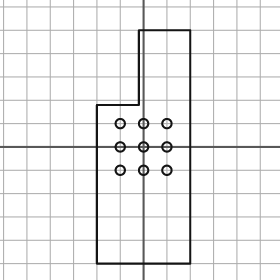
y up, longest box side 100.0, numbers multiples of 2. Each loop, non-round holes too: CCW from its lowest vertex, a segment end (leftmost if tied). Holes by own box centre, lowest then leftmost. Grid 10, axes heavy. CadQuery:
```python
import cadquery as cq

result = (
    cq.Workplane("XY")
    .moveTo(-20.0, -50.0)
    .lineTo(20.0, -50.0)
    .lineTo(20.0, 50.0)
    .lineTo(-2.0, 50.0)
    .lineTo(-2.0, 18.0)
    .lineTo(-20.0, 18.0)
    .close()
    .moveTo(-10.0, -10.0)
    .circle(2.0)
    .moveTo(0.0, -10.0)
    .circle(2.0)
    .moveTo(10.0, -10.0)
    .circle(2.0)
    .moveTo(-10.0, 0.0)
    .circle(2.0)
    .moveTo(0.0, 0.0)
    .circle(2.0)
    .moveTo(10.0, 0.0)
    .circle(2.0)
    .moveTo(-10.0, 10.0)
    .circle(2.0)
    .moveTo(0.0, 10.0)
    .circle(2.0)
    .moveTo(10.0, 10.0)
    .circle(2.0)
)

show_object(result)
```